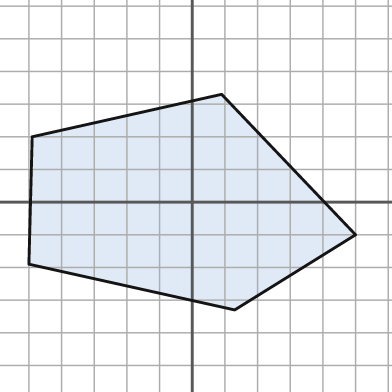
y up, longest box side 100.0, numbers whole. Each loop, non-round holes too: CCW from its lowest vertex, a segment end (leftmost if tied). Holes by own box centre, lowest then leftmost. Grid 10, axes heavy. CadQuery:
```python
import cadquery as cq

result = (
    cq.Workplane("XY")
    .moveTo(13.0, -33.0)
    .lineTo(50.0, -10.0)
    .lineTo(9.0, 33.0)
    .lineTo(-49.0, 20.0)
    .lineTo(-50.0, -19.0)
    .close()
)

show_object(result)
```